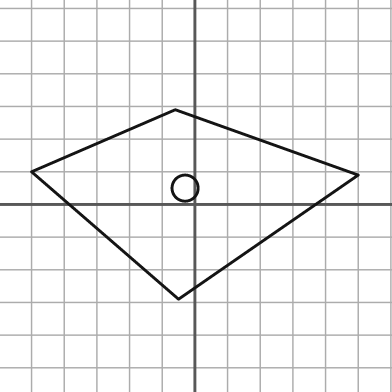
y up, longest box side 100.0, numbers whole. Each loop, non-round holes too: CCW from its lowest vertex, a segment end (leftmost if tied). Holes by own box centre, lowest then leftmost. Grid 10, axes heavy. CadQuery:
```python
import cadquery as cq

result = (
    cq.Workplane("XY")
    .moveTo(-5.0, -29.0)
    .lineTo(50.0, 9.0)
    .lineTo(-6.0, 29.0)
    .lineTo(-50.0, 10.0)
    .close()
    .moveTo(-3.0, 5.0)
    .circle(4.0)
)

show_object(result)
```